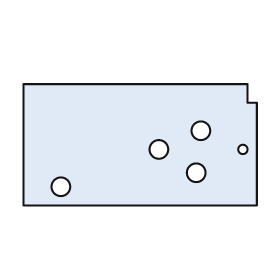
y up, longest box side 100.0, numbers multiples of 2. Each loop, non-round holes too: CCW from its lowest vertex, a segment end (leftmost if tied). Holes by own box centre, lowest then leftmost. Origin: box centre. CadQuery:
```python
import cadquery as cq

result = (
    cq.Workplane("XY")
    .moveTo(-50.0, -26.0)
    .lineTo(50.0, -26.0)
    .lineTo(50.0, 18.0)
    .lineTo(46.0, 18.0)
    .lineTo(46.0, 26.0)
    .lineTo(-50.0, 26.0)
    .close()
    .moveTo(-34.0, -18.0)
    .circle(4.0)
    .moveTo(24.0, -12.0)
    .circle(4.0)
    .moveTo(8.0, -2.0)
    .circle(4.0)
    .moveTo(44.0, -2.0)
    .circle(2.0)
    .moveTo(26.0, 6.0)
    .circle(4.0)
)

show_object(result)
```